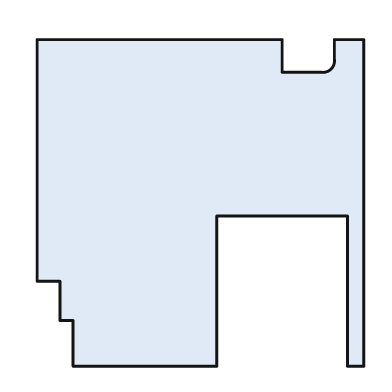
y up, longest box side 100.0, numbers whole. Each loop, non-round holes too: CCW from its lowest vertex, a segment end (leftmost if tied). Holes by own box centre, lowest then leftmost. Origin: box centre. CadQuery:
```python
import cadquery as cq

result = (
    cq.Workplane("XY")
    .moveTo(-39.0, -50.0)
    .lineTo(5.0, -50.0)
    .lineTo(5.0, -4.0)
    .lineTo(45.0, -4.0)
    .lineTo(45.0, -50.0)
    .lineTo(50.0, -50.0)
    .lineTo(50.0, 50.0)
    .lineTo(41.0, 50.0)
    .lineTo(41.0, 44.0)
    .threePointArc((40.0, 41.0), (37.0, 40.0))
    .lineTo(25.0, 40.0)
    .lineTo(25.0, 50.0)
    .lineTo(-50.0, 50.0)
    .lineTo(-50.0, -24.0)
    .lineTo(-43.0, -24.0)
    .lineTo(-43.0, -36.0)
    .lineTo(-39.0, -36.0)
    .close()
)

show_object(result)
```